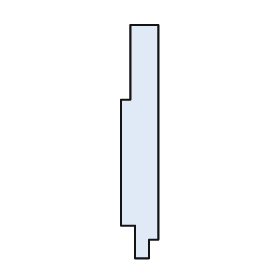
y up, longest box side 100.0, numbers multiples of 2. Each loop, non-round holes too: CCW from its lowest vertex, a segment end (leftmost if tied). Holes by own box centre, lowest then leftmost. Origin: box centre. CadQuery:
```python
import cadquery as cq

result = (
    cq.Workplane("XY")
    .moveTo(-2.0, -50.0)
    .lineTo(4.0, -50.0)
    .lineTo(4.0, -42.0)
    .lineTo(8.0, -42.0)
    .lineTo(8.0, 50.0)
    .lineTo(-4.0, 50.0)
    .lineTo(-4.0, 18.0)
    .lineTo(-8.0, 18.0)
    .lineTo(-8.0, -36.0)
    .lineTo(-2.0, -36.0)
    .close()
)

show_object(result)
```